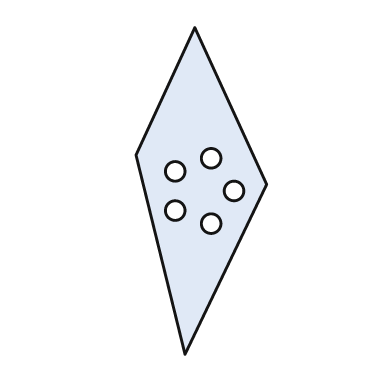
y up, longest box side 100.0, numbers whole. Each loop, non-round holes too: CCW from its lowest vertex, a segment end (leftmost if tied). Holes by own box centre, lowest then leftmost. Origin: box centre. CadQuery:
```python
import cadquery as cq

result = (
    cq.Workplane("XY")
    .moveTo(-5.0, -50.0)
    .lineTo(20.0, 2.0)
    .lineTo(-2.0, 50.0)
    .lineTo(-20.0, 11.0)
    .close()
    .moveTo(3.0, -10.0)
    .circle(3.0)
    .moveTo(-8.0, -6.0)
    .circle(3.0)
    .moveTo(10.0, 0.0)
    .circle(3.0)
    .moveTo(-8.0, 6.0)
    .circle(3.0)
    .moveTo(3.0, 10.0)
    .circle(3.0)
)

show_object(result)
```